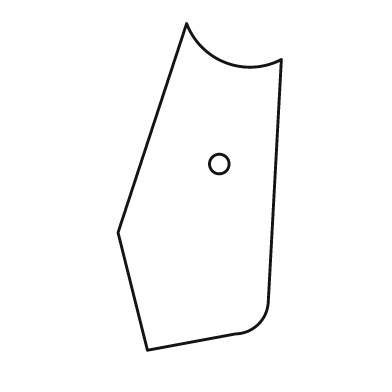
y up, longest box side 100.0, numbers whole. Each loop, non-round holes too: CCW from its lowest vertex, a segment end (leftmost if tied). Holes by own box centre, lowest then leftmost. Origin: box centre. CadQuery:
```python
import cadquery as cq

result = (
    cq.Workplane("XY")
    .moveTo(-16.0, -50.0)
    .lineTo(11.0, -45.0)
    .threePointArc((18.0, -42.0), (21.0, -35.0))
    .lineTo(25.0, 39.0)
    .threePointArc((8.0, 38.0), (-4.0, 50.0))
    .lineTo(-25.0, -14.0)
    .close()
    .moveTo(6.0, 7.0)
    .circle(3.0)
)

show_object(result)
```